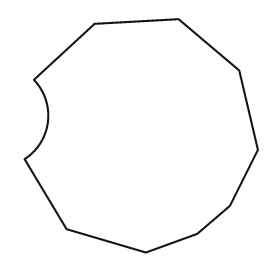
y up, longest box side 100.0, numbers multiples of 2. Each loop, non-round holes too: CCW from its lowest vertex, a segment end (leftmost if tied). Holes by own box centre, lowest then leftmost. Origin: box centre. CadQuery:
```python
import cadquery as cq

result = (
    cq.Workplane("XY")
    .moveTo(2.0, -50.0)
    .lineTo(24.0, -42.0)
    .lineTo(38.0, -30.0)
    .lineTo(50.0, -6.0)
    .lineTo(42.0, 28.0)
    .lineTo(16.0, 50.0)
    .lineTo(-20.0, 48.0)
    .lineTo(-46.0, 24.0)
    .threePointArc((-40.0, 6.0), (-50.0, -10.0))
    .lineTo(-32.0, -40.0)
    .close()
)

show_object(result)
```